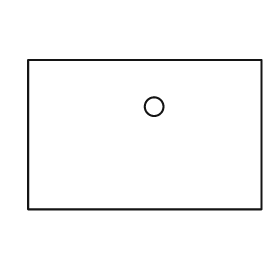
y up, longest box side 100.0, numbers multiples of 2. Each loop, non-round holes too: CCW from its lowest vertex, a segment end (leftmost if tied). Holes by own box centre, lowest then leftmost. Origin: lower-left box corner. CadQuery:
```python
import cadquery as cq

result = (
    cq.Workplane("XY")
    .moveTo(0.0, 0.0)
    .lineTo(100.0, 0.0)
    .lineTo(100.0, 64.0)
    .lineTo(0.0, 64.0)
    .close()
    .moveTo(54.0, 44.0)
    .circle(4.0)
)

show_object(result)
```